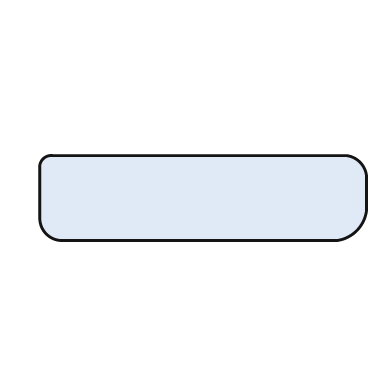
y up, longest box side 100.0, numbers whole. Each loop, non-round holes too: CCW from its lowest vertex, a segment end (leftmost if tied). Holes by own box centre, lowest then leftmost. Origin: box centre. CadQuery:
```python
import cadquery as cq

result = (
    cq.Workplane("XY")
    .moveTo(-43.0, -13.0)
    .lineTo(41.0, -13.0)
    .threePointArc((47.0, -10.0), (50.0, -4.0))
    .lineTo(50.0, 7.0)
    .threePointArc((48.0, 11.0), (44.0, 13.0))
    .lineTo(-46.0, 13.0)
    .threePointArc((-49.0, 12.0), (-50.0, 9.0))
    .lineTo(-50.0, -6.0)
    .threePointArc((-48.0, -11.0), (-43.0, -13.0))
    .close()
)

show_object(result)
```